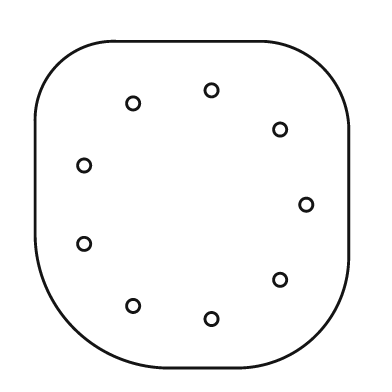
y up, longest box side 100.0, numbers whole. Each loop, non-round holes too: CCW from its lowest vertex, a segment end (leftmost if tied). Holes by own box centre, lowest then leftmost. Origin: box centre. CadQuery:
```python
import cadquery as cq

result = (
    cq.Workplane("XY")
    .moveTo(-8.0, -50.0)
    .lineTo(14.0, -50.0)
    .threePointArc((38.0, -40.0), (48.0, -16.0))
    .lineTo(48.0, 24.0)
    .threePointArc((40.0, 42.0), (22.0, 50.0))
    .lineTo(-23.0, 50.0)
    .threePointArc((-41.0, 43.0), (-48.0, 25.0))
    .lineTo(-48.0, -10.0)
    .threePointArc((-36.0, -38.0), (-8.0, -50.0))
    .close()
    .moveTo(6.0, -35.0)
    .circle(2.0)
    .moveTo(-18.0, -31.0)
    .circle(2.0)
    .moveTo(27.0, -23.0)
    .circle(2.0)
    .moveTo(-33.0, -12.0)
    .circle(2.0)
    .moveTo(35.0, 0.0)
    .circle(2.0)
    .moveTo(-33.0, 12.0)
    .circle(2.0)
    .moveTo(27.0, 23.0)
    .circle(2.0)
    .moveTo(-18.0, 31.0)
    .circle(2.0)
    .moveTo(6.0, 35.0)
    .circle(2.0)
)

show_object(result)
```